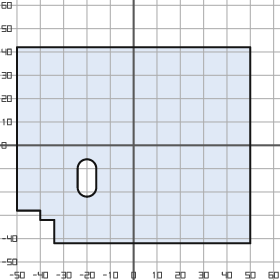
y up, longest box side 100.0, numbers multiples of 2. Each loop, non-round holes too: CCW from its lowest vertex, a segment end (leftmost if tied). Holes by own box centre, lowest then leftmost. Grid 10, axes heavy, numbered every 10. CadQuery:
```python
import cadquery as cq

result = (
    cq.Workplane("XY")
    .moveTo(-34.0, -42.0)
    .lineTo(50.0, -42.0)
    .lineTo(50.0, 42.0)
    .lineTo(-50.0, 42.0)
    .lineTo(-50.0, -28.0)
    .lineTo(-40.0, -28.0)
    .lineTo(-40.0, -32.0)
    .lineTo(-34.0, -32.0)
    .close()
    .moveTo(-24.0, -18.0)
    .threePointArc((-20.0, -22.0), (-16.0, -18.0))
    .lineTo(-16.0, -10.0)
    .threePointArc((-20.0, -6.0), (-24.0, -10.0))
    .close()
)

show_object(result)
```